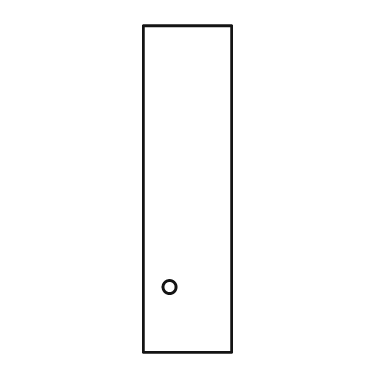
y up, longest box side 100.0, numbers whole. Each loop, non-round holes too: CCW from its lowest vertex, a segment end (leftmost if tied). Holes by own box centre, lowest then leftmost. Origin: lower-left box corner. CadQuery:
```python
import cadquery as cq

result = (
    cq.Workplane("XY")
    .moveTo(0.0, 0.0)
    .lineTo(27.0, 0.0)
    .lineTo(27.0, 100.0)
    .lineTo(0.0, 100.0)
    .close()
    .moveTo(8.0, 20.0)
    .circle(2.0)
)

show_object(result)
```